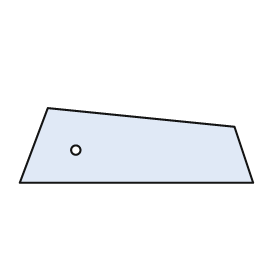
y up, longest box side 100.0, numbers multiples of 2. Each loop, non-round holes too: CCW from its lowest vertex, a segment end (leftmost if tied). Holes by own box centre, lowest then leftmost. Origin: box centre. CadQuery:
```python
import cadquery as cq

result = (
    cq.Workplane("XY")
    .moveTo(-50.0, -16.0)
    .lineTo(50.0, -16.0)
    .lineTo(42.0, 8.0)
    .lineTo(-38.0, 16.0)
    .close()
    .moveTo(-26.0, -2.0)
    .circle(2.0)
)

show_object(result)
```